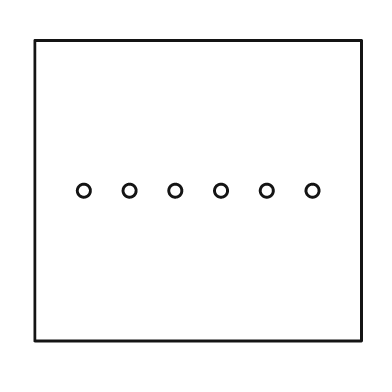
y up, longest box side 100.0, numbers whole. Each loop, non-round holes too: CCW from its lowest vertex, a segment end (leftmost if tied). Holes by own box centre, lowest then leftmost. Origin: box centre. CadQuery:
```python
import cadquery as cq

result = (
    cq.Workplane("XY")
    .moveTo(-50.0, -46.0)
    .lineTo(50.0, -46.0)
    .lineTo(50.0, 46.0)
    .lineTo(-50.0, 46.0)
    .close()
    .moveTo(-35.0, 0.0)
    .circle(2.0)
    .moveTo(-21.0, 0.0)
    .circle(2.0)
    .moveTo(-7.0, 0.0)
    .circle(2.0)
    .moveTo(7.0, 0.0)
    .circle(2.0)
    .moveTo(21.0, 0.0)
    .circle(2.0)
    .moveTo(35.0, 0.0)
    .circle(2.0)
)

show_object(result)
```